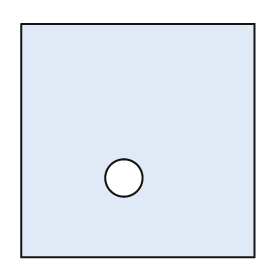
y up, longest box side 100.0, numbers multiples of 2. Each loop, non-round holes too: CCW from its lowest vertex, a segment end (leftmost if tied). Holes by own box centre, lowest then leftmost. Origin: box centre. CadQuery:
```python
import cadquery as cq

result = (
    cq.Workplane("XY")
    .moveTo(-50.0, -50.0)
    .lineTo(50.0, -50.0)
    .lineTo(50.0, 50.0)
    .lineTo(-50.0, 50.0)
    .close()
    .moveTo(-6.0, -16.0)
    .circle(8.0)
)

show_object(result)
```